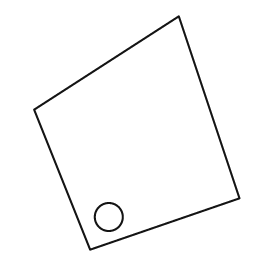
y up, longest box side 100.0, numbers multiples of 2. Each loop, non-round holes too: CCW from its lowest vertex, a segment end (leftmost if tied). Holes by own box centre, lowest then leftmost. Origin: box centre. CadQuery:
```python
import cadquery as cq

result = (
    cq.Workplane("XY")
    .moveTo(-20.0, -50.0)
    .lineTo(44.0, -28.0)
    .lineTo(18.0, 50.0)
    .lineTo(-44.0, 10.0)
    .close()
    .moveTo(-12.0, -36.0)
    .circle(6.0)
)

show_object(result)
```